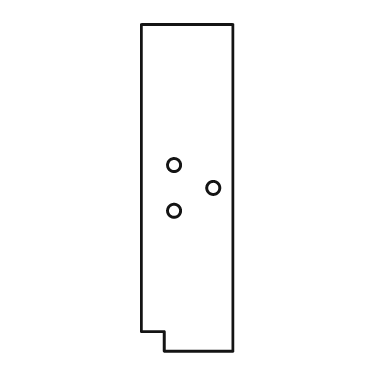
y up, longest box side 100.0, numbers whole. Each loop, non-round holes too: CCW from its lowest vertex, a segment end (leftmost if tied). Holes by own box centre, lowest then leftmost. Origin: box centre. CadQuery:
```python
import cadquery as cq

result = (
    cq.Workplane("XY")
    .moveTo(-7.0, -50.0)
    .lineTo(14.0, -50.0)
    .lineTo(14.0, 50.0)
    .lineTo(-14.0, 50.0)
    .lineTo(-14.0, -44.0)
    .lineTo(-7.0, -44.0)
    .close()
    .moveTo(-4.0, -7.0)
    .circle(2.0)
    .moveTo(8.0, 0.0)
    .circle(2.0)
    .moveTo(-4.0, 7.0)
    .circle(2.0)
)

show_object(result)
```